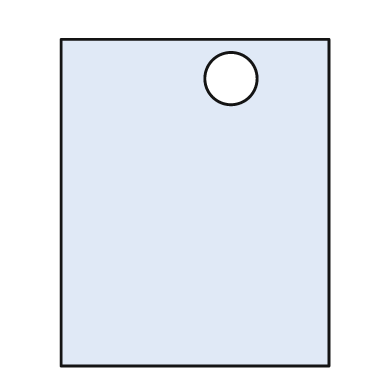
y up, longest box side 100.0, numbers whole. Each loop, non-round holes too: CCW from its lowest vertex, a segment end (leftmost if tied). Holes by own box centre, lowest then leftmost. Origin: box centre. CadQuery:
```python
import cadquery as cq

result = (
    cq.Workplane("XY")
    .moveTo(-41.0, -50.0)
    .lineTo(41.0, -50.0)
    .lineTo(41.0, 50.0)
    .lineTo(-41.0, 50.0)
    .close()
    .moveTo(11.0, 38.0)
    .circle(8.0)
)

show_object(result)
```